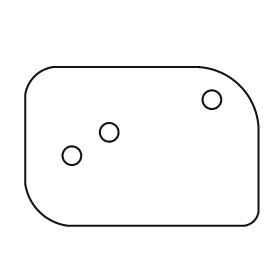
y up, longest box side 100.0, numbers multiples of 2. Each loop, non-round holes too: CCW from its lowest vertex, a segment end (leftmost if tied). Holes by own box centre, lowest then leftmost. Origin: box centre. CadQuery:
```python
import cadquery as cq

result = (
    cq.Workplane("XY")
    .moveTo(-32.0, -34.0)
    .lineTo(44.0, -34.0)
    .threePointArc((48.0, -32.0), (50.0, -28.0))
    .lineTo(50.0, 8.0)
    .threePointArc((42.0, 26.0), (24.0, 34.0))
    .lineTo(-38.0, 34.0)
    .threePointArc((-46.0, 30.0), (-50.0, 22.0))
    .lineTo(-50.0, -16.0)
    .threePointArc((-44.0, -28.0), (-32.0, -34.0))
    .close()
    .moveTo(-30.0, -4.0)
    .circle(4.0)
    .moveTo(-14.0, 6.0)
    .circle(4.0)
    .moveTo(30.0, 20.0)
    .circle(4.0)
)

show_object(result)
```